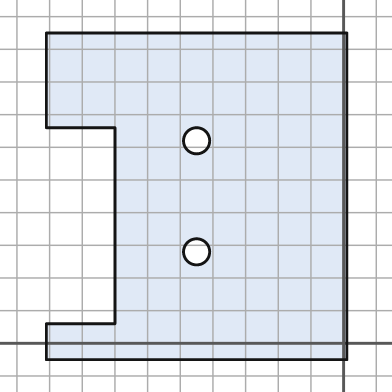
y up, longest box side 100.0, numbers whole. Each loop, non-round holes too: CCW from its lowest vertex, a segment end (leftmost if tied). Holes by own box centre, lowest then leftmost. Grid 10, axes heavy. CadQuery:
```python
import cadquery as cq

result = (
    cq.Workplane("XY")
    .moveTo(-91.0, -5.0)
    .lineTo(1.0, -5.0)
    .lineTo(1.0, 95.0)
    .lineTo(-91.0, 95.0)
    .lineTo(-91.0, 66.0)
    .lineTo(-70.0, 66.0)
    .lineTo(-70.0, 6.0)
    .lineTo(-91.0, 6.0)
    .close()
    .moveTo(-45.0, 28.0)
    .circle(4.0)
    .moveTo(-45.0, 62.0)
    .circle(4.0)
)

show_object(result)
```